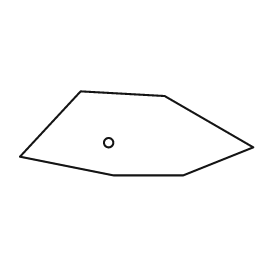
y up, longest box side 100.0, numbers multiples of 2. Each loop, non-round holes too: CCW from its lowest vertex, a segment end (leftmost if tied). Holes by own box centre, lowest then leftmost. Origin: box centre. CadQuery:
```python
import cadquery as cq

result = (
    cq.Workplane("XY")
    .moveTo(-10.0, -18.0)
    .lineTo(20.0, -18.0)
    .lineTo(50.0, -6.0)
    .lineTo(12.0, 16.0)
    .lineTo(-24.0, 18.0)
    .lineTo(-50.0, -10.0)
    .close()
    .moveTo(-12.0, -4.0)
    .circle(2.0)
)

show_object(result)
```